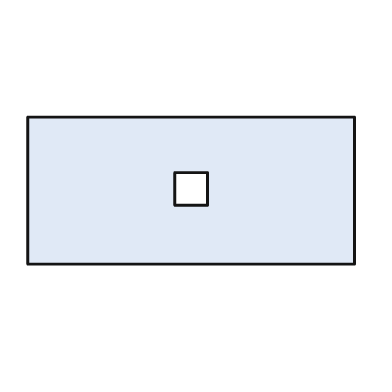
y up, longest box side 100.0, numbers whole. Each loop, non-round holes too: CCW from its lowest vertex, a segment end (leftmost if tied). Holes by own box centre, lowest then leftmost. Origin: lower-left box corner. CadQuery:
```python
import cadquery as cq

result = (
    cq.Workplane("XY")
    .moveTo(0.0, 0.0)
    .lineTo(100.0, 0.0)
    .lineTo(100.0, 45.0)
    .lineTo(0.0, 45.0)
    .close()
    .moveTo(45.0, 18.0)
    .lineTo(55.0, 18.0)
    .lineTo(55.0, 28.0)
    .lineTo(45.0, 28.0)
    .close()
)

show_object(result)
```